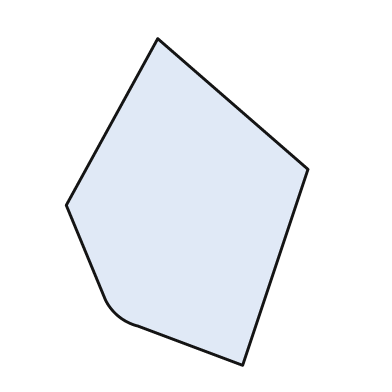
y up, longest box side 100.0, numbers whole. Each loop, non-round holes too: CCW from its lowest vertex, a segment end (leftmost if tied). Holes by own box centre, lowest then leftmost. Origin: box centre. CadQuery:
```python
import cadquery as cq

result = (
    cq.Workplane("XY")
    .moveTo(17.0, -50.0)
    .lineTo(37.0, 10.0)
    .lineTo(-9.0, 50.0)
    .lineTo(-37.0, -1.0)
    .lineTo(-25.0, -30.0)
    .threePointArc((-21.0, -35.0), (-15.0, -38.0))
    .close()
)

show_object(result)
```